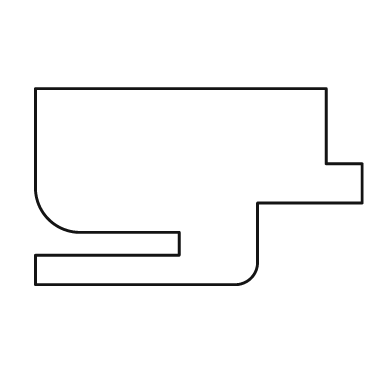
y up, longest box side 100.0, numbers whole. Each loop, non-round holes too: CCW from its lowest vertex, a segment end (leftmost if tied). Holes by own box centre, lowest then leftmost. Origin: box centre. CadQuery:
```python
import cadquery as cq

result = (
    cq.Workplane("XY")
    .moveTo(-50.0, -30.0)
    .lineTo(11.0, -30.0)
    .threePointArc((16.0, -28.0), (18.0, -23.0))
    .lineTo(18.0, -5.0)
    .lineTo(50.0, -5.0)
    .lineTo(50.0, 7.0)
    .lineTo(39.0, 7.0)
    .lineTo(39.0, 30.0)
    .lineTo(-50.0, 30.0)
    .lineTo(-50.0, 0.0)
    .threePointArc((-46.0, -10.0), (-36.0, -14.0))
    .lineTo(-6.0, -14.0)
    .lineTo(-6.0, -21.0)
    .lineTo(-50.0, -21.0)
    .close()
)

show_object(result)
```